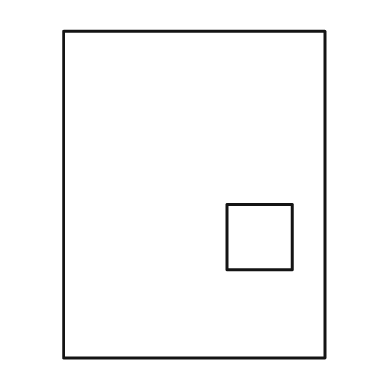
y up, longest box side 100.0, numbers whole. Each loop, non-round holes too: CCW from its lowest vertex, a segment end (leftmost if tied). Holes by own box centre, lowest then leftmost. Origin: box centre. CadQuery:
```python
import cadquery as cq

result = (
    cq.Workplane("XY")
    .moveTo(-40.0, -50.0)
    .lineTo(40.0, -50.0)
    .lineTo(40.0, 50.0)
    .lineTo(-40.0, 50.0)
    .close()
    .moveTo(10.0, -23.0)
    .lineTo(30.0, -23.0)
    .lineTo(30.0, -3.0)
    .lineTo(10.0, -3.0)
    .close()
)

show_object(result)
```